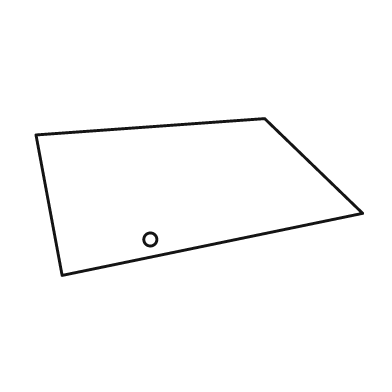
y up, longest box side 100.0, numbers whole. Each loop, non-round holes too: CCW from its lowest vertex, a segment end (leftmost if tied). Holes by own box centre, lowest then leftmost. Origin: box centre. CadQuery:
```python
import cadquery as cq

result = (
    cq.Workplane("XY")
    .moveTo(-42.0, -24.0)
    .lineTo(50.0, -5.0)
    .lineTo(20.0, 24.0)
    .lineTo(-50.0, 19.0)
    .close()
    .moveTo(-15.0, -13.0)
    .circle(2.0)
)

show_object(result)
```